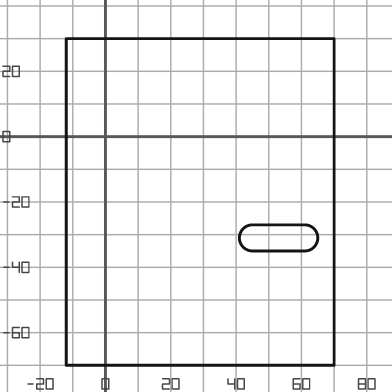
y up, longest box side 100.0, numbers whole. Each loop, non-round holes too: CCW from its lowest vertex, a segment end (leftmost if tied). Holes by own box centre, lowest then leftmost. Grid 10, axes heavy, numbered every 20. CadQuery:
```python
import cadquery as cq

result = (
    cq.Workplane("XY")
    .moveTo(-12.0, -70.0)
    .lineTo(70.0, -70.0)
    .lineTo(70.0, 30.0)
    .lineTo(-12.0, 30.0)
    .close()
    .moveTo(45.0, -35.0)
    .lineTo(61.0, -35.0)
    .threePointArc((65.0, -31.0), (61.0, -27.0))
    .lineTo(45.0, -27.0)
    .threePointArc((41.0, -31.0), (45.0, -35.0))
    .close()
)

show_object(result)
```